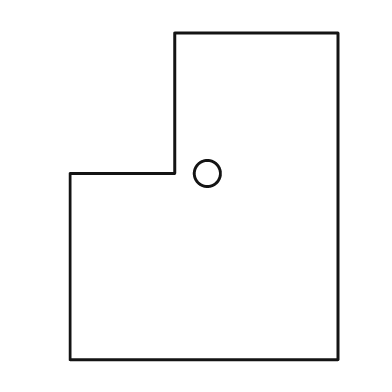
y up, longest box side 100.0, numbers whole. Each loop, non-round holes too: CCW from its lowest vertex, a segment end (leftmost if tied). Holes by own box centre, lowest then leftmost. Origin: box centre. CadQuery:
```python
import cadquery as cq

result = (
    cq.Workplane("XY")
    .moveTo(-41.0, -50.0)
    .lineTo(41.0, -50.0)
    .lineTo(41.0, 50.0)
    .lineTo(-9.0, 50.0)
    .lineTo(-9.0, 7.0)
    .lineTo(-41.0, 7.0)
    .close()
    .moveTo(1.0, 7.0)
    .circle(4.0)
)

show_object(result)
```